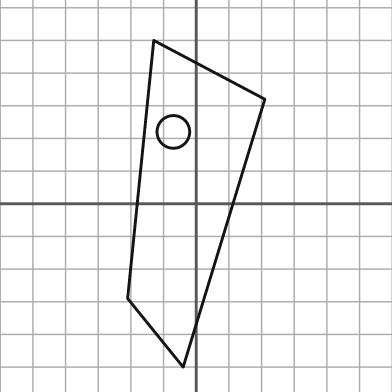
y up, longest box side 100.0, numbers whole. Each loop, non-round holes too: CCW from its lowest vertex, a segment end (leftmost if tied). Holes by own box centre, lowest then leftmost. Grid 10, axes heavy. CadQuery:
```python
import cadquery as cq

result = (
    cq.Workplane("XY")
    .moveTo(-4.0, -50.0)
    .lineTo(21.0, 32.0)
    .lineTo(-13.0, 50.0)
    .lineTo(-21.0, -29.0)
    .close()
    .moveTo(-7.0, 22.0)
    .circle(5.0)
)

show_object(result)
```